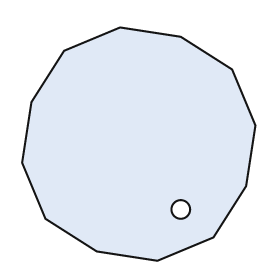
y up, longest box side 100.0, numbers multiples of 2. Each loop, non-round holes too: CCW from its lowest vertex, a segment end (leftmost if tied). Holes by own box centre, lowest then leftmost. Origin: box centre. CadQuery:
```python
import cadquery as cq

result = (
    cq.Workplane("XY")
    .moveTo(8.0, -50.0)
    .lineTo(32.0, -40.0)
    .lineTo(46.0, -18.0)
    .lineTo(50.0, 8.0)
    .lineTo(40.0, 32.0)
    .lineTo(18.0, 46.0)
    .lineTo(-8.0, 50.0)
    .lineTo(-32.0, 40.0)
    .lineTo(-46.0, 18.0)
    .lineTo(-50.0, -8.0)
    .lineTo(-40.0, -32.0)
    .lineTo(-18.0, -46.0)
    .close()
    .moveTo(18.0, -28.0)
    .circle(4.0)
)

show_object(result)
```